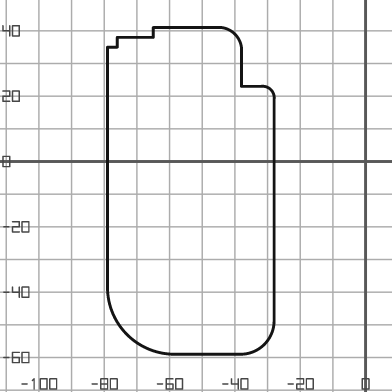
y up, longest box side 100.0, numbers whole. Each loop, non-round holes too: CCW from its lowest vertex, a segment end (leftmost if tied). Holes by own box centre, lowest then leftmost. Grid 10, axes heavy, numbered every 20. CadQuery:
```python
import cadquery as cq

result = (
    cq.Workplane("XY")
    .moveTo(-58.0, -59.0)
    .lineTo(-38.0, -59.0)
    .threePointArc((-31.0, -56.0), (-28.0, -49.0))
    .lineTo(-28.0, 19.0)
    .threePointArc((-29.0, 22.0), (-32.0, 23.0))
    .lineTo(-38.0, 23.0)
    .lineTo(-38.0, 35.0)
    .threePointArc((-40.0, 39.0), (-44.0, 41.0))
    .lineTo(-65.0, 41.0)
    .lineTo(-65.0, 38.0)
    .lineTo(-76.0, 38.0)
    .lineTo(-76.0, 35.0)
    .lineTo(-79.0, 35.0)
    .lineTo(-79.0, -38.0)
    .threePointArc((-73.0, -53.0), (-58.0, -59.0))
    .close()
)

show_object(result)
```